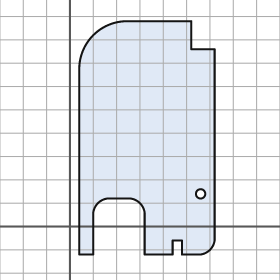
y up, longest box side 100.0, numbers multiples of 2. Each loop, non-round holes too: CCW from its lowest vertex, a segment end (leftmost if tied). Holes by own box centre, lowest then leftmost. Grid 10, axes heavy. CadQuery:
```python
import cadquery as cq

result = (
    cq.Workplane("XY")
    .moveTo(4.0, -12.0)
    .lineTo(10.0, -12.0)
    .lineTo(10.0, 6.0)
    .threePointArc((12.0, 10.0), (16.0, 12.0))
    .lineTo(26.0, 12.0)
    .threePointArc((30.0, 10.0), (32.0, 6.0))
    .lineTo(32.0, -12.0)
    .lineTo(44.0, -12.0)
    .lineTo(44.0, -6.0)
    .lineTo(48.0, -6.0)
    .lineTo(48.0, -12.0)
    .lineTo(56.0, -12.0)
    .threePointArc((60.0, -10.0), (62.0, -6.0))
    .lineTo(62.0, 76.0)
    .lineTo(52.0, 76.0)
    .lineTo(52.0, 88.0)
    .lineTo(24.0, 88.0)
    .threePointArc((10.0, 82.0), (4.0, 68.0))
    .close()
    .moveTo(56.0, 14.0)
    .circle(2.0)
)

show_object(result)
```